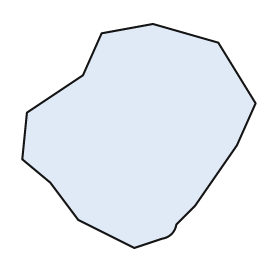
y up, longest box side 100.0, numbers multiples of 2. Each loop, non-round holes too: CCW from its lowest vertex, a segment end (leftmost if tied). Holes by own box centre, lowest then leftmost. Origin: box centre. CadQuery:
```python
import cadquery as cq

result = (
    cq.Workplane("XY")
    .moveTo(-2.0, -48.0)
    .lineTo(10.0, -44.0)
    .threePointArc((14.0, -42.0), (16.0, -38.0))
    .lineTo(24.0, -30.0)
    .lineTo(42.0, -4.0)
    .lineTo(50.0, 14.0)
    .lineTo(34.0, 40.0)
    .lineTo(6.0, 48.0)
    .lineTo(-16.0, 44.0)
    .lineTo(-24.0, 26.0)
    .lineTo(-48.0, 10.0)
    .lineTo(-50.0, -10.0)
    .lineTo(-38.0, -20.0)
    .lineTo(-26.0, -36.0)
    .close()
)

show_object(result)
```